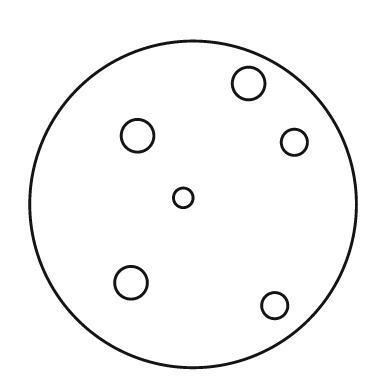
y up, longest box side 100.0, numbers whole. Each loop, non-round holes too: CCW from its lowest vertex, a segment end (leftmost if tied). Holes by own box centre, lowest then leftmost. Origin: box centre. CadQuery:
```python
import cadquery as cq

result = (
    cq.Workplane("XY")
    .moveTo(0.0, 0.0)
    .circle(50.0)
    .moveTo(25.0, -31.0)
    .circle(4.0)
    .moveTo(-19.0, -24.0)
    .circle(5.0)
    .moveTo(-3.0, 2.0)
    .circle(3.0)
    .moveTo(31.0, 19.0)
    .circle(4.0)
    .moveTo(-17.0, 21.0)
    .circle(5.0)
    .moveTo(17.0, 37.0)
    .circle(5.0)
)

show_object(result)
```